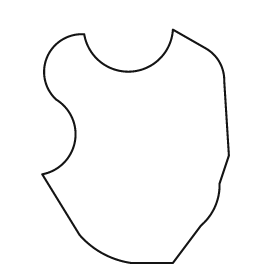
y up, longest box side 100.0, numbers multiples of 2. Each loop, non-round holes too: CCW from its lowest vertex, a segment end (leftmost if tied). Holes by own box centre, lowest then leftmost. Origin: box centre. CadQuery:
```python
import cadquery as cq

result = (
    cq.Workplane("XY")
    .moveTo(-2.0, -50.0)
    .lineTo(16.0, -50.0)
    .lineTo(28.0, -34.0)
    .threePointArc((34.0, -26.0), (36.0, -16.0))
    .lineTo(40.0, -4.0)
    .lineTo(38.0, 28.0)
    .threePointArc((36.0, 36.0), (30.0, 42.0))
    .lineTo(16.0, 50.0)
    .threePointArc((-2.0, 32.0), (-22.0, 48.0))
    .threePointArc((-38.0, 38.0), (-34.0, 20.0))
    .threePointArc((-26.0, 2.0), (-40.0, -12.0))
    .lineTo(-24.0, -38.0)
    .threePointArc((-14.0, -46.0), (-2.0, -50.0))
    .close()
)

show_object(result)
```